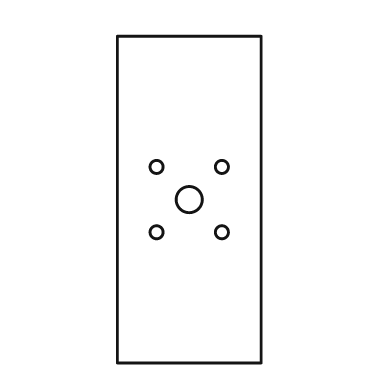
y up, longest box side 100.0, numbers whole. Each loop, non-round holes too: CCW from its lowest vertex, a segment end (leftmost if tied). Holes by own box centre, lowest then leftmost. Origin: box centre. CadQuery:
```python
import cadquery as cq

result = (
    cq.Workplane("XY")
    .moveTo(-22.0, -50.0)
    .lineTo(22.0, -50.0)
    .lineTo(22.0, 50.0)
    .lineTo(-22.0, 50.0)
    .close()
    .moveTo(-10.0, -10.0)
    .circle(2.0)
    .moveTo(10.0, -10.0)
    .circle(2.0)
    .moveTo(0.0, 0.0)
    .circle(4.0)
    .moveTo(-10.0, 10.0)
    .circle(2.0)
    .moveTo(10.0, 10.0)
    .circle(2.0)
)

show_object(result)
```